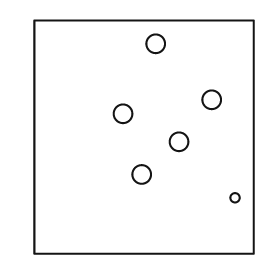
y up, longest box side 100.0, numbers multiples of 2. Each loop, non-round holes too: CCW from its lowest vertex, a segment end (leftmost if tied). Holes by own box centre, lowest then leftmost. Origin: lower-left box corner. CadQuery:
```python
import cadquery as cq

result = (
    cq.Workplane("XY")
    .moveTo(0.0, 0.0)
    .lineTo(94.0, 0.0)
    .lineTo(94.0, 100.0)
    .lineTo(0.0, 100.0)
    .close()
    .moveTo(86.0, 24.0)
    .circle(2.0)
    .moveTo(46.0, 34.0)
    .circle(4.0)
    .moveTo(62.0, 48.0)
    .circle(4.0)
    .moveTo(38.0, 60.0)
    .circle(4.0)
    .moveTo(76.0, 66.0)
    .circle(4.0)
    .moveTo(52.0, 90.0)
    .circle(4.0)
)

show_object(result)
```